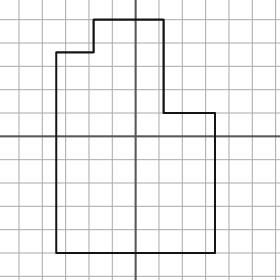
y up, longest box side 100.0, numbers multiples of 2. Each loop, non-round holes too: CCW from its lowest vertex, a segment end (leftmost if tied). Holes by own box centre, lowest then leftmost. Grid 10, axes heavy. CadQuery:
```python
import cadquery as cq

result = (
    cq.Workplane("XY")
    .moveTo(-34.0, -50.0)
    .lineTo(34.0, -50.0)
    .lineTo(34.0, 10.0)
    .lineTo(12.0, 10.0)
    .lineTo(12.0, 50.0)
    .lineTo(-18.0, 50.0)
    .lineTo(-18.0, 36.0)
    .lineTo(-34.0, 36.0)
    .close()
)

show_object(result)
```